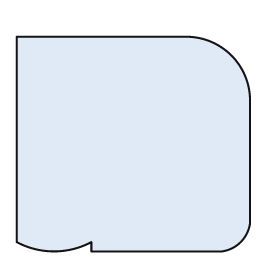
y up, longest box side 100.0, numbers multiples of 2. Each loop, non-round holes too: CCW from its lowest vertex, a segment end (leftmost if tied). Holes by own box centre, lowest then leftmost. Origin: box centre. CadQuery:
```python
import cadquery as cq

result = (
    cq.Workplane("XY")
    .moveTo(-18.0, -46.0)
    .lineTo(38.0, -46.0)
    .threePointArc((46.0, -42.0), (50.0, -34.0))
    .lineTo(50.0, 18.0)
    .threePointArc((42.0, 38.0), (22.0, 46.0))
    .lineTo(-50.0, 46.0)
    .lineTo(-50.0, -42.0)
    .threePointArc((-34.0, -46.0), (-18.0, -42.0))
    .close()
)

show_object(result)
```